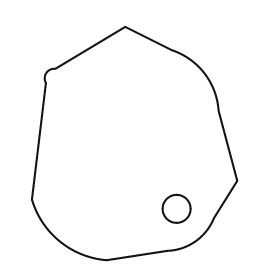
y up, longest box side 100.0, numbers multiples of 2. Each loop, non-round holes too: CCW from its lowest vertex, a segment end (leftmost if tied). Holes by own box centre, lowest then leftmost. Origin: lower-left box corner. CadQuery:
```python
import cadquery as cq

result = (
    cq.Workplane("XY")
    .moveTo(32.0, 0.0)
    .lineTo(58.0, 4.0)
    .threePointArc((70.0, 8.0), (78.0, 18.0))
    .lineTo(88.0, 34.0)
    .lineTo(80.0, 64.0)
    .threePointArc((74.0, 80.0), (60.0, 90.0))
    .lineTo(40.0, 100.0)
    .lineTo(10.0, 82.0)
    .threePointArc((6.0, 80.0), (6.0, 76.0))
    .lineTo(0.0, 26.0)
    .threePointArc((12.0, 8.0), (32.0, 0.0))
    .close()
    .moveTo(62.0, 22.0)
    .circle(6.0)
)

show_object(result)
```